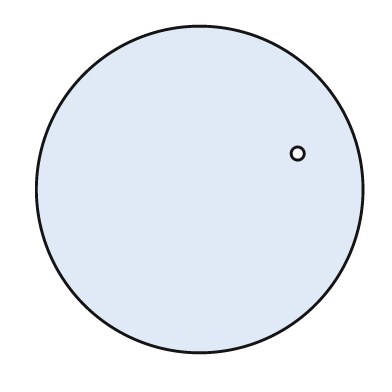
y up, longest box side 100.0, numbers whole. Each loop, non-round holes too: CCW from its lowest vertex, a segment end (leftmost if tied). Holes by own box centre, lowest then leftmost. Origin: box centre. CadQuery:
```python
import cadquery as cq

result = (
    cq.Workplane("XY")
    .moveTo(0.0, 0.0)
    .circle(50.0)
    .moveTo(30.0, 11.0)
    .circle(2.0)
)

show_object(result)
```